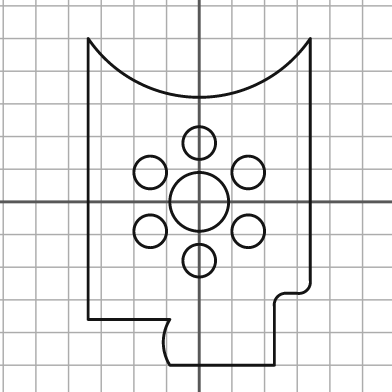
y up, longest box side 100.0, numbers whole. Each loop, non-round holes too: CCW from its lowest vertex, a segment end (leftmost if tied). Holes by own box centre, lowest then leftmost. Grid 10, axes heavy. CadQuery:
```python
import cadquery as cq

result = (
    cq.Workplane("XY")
    .moveTo(-9.0, -50.0)
    .lineTo(23.0, -50.0)
    .lineTo(23.0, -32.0)
    .threePointArc((24.0, -29.0), (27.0, -28.0))
    .lineTo(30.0, -28.0)
    .threePointArc((33.0, -27.0), (34.0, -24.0))
    .lineTo(34.0, 50.0)
    .threePointArc((0.0, 32.0), (-34.0, 50.0))
    .lineTo(-34.0, -36.0)
    .lineTo(-9.0, -36.0)
    .threePointArc((-11.0, -43.0), (-9.0, -50.0))
    .close()
    .moveTo(0.0, -18.0)
    .circle(5.0)
    .moveTo(-15.0, -9.0)
    .circle(5.0)
    .moveTo(15.0, -9.0)
    .circle(5.0)
    .moveTo(0.0, 0.0)
    .circle(9.0)
    .moveTo(-15.0, 9.0)
    .circle(5.0)
    .moveTo(15.0, 9.0)
    .circle(5.0)
    .moveTo(0.0, 18.0)
    .circle(5.0)
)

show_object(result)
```